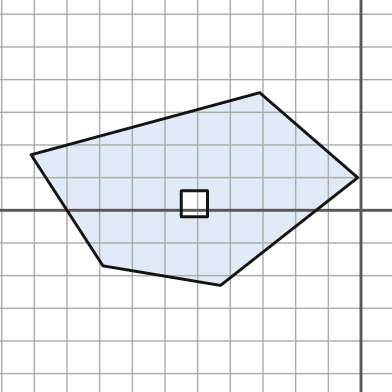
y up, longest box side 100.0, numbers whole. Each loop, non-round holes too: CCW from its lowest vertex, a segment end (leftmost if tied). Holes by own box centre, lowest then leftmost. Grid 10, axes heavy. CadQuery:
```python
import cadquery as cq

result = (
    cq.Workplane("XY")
    .moveTo(-43.0, -23.0)
    .lineTo(-1.0, 10.0)
    .lineTo(-31.0, 36.0)
    .lineTo(-101.0, 17.0)
    .lineTo(-79.0, -17.0)
    .close()
    .moveTo(-55.0, -2.0)
    .lineTo(-47.0, -2.0)
    .lineTo(-47.0, 6.0)
    .lineTo(-55.0, 6.0)
    .close()
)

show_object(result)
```